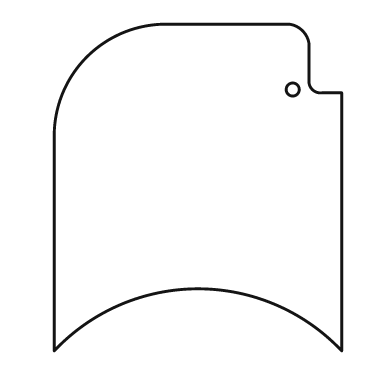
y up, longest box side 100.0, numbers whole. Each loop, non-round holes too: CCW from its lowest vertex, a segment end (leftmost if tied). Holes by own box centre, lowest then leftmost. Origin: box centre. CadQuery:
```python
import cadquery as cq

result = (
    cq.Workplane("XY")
    .moveTo(-44.0, -50.0)
    .threePointArc((0.0, -31.0), (44.0, -50.0))
    .lineTo(44.0, 29.0)
    .lineTo(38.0, 29.0)
    .threePointArc((35.0, 30.0), (34.0, 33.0))
    .lineTo(34.0, 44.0)
    .threePointArc((32.0, 48.0), (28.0, 50.0))
    .lineTo(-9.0, 50.0)
    .threePointArc((-34.0, 40.0), (-44.0, 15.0))
    .close()
    .moveTo(29.0, 30.0)
    .circle(2.0)
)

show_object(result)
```